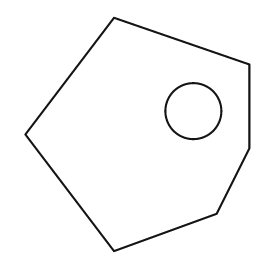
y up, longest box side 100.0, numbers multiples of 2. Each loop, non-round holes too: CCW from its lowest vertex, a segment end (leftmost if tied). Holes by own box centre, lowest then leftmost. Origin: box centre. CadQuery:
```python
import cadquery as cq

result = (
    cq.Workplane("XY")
    .moveTo(-10.0, -50.0)
    .lineTo(34.0, -34.0)
    .lineTo(48.0, -6.0)
    .lineTo(48.0, 30.0)
    .lineTo(-10.0, 50.0)
    .lineTo(-48.0, 0.0)
    .close()
    .moveTo(24.0, 10.0)
    .circle(12.0)
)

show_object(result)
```